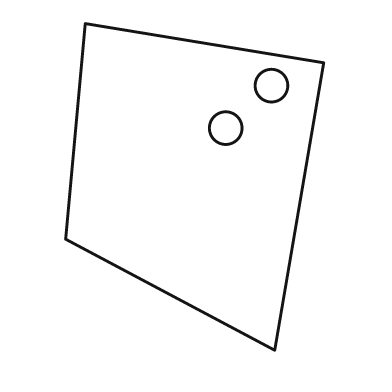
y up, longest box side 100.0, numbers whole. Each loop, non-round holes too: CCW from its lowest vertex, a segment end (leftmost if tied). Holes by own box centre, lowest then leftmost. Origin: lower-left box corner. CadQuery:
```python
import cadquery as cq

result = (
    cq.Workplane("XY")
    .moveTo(64.0, 0.0)
    .lineTo(79.0, 88.0)
    .lineTo(6.0, 100.0)
    .lineTo(0.0, 34.0)
    .close()
    .moveTo(49.0, 68.0)
    .circle(5.0)
    .moveTo(63.0, 81.0)
    .circle(5.0)
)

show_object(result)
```